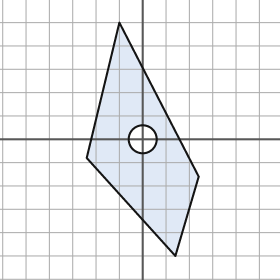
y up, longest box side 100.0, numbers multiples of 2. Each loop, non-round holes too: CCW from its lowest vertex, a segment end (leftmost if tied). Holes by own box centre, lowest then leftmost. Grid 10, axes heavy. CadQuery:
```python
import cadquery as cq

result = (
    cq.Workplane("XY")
    .moveTo(14.0, -50.0)
    .lineTo(24.0, -16.0)
    .lineTo(-10.0, 50.0)
    .lineTo(-24.0, -8.0)
    .close()
    .moveTo(0.0, 0.0)
    .circle(6.0)
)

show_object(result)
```